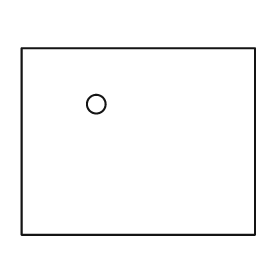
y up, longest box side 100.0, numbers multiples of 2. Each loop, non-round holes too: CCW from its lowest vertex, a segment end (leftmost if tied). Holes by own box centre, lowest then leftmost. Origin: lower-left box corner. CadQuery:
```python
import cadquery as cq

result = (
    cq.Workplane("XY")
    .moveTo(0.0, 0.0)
    .lineTo(100.0, 0.0)
    .lineTo(100.0, 80.0)
    .lineTo(0.0, 80.0)
    .close()
    .moveTo(32.0, 56.0)
    .circle(4.0)
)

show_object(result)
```